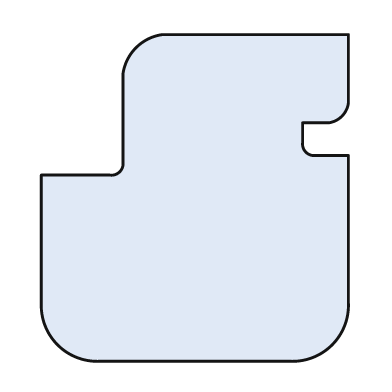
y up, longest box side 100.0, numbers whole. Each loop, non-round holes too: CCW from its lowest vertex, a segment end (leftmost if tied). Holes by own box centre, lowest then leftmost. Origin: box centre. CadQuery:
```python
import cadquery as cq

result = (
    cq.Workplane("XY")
    .moveTo(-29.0, -50.0)
    .lineTo(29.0, -50.0)
    .threePointArc((42.0, -45.0), (47.0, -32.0))
    .lineTo(47.0, 13.0)
    .lineTo(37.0, 13.0)
    .threePointArc((34.0, 14.0), (33.0, 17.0))
    .lineTo(33.0, 23.0)
    .lineTo(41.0, 23.0)
    .threePointArc((45.0, 25.0), (47.0, 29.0))
    .lineTo(47.0, 50.0)
    .lineTo(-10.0, 50.0)
    .threePointArc((-18.0, 46.0), (-22.0, 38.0))
    .lineTo(-22.0, 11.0)
    .threePointArc((-23.0, 8.0), (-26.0, 7.0))
    .lineTo(-47.0, 7.0)
    .lineTo(-47.0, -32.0)
    .threePointArc((-42.0, -45.0), (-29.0, -50.0))
    .close()
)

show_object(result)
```